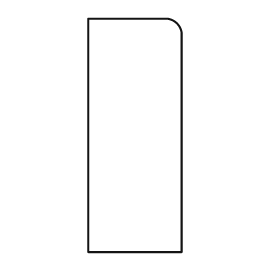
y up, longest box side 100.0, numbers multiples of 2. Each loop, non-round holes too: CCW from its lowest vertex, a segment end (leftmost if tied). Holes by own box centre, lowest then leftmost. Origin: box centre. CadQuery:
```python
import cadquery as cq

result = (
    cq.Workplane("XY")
    .moveTo(-20.0, -50.0)
    .lineTo(20.0, -50.0)
    .lineTo(20.0, 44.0)
    .threePointArc((18.0, 48.0), (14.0, 50.0))
    .lineTo(-20.0, 50.0)
    .close()
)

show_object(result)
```